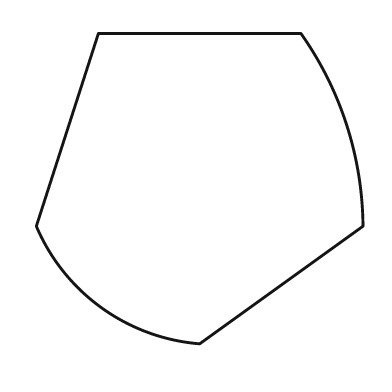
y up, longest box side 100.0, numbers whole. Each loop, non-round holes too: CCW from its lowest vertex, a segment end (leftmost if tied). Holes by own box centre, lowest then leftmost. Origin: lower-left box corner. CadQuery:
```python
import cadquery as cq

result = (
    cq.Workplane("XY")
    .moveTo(50.0, 0.0)
    .lineTo(100.0, 36.0)
    .threePointArc((95.0, 67.0), (81.0, 95.0))
    .lineTo(19.0, 95.0)
    .lineTo(0.0, 36.0)
    .threePointArc((20.0, 11.0), (50.0, 0.0))
    .close()
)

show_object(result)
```